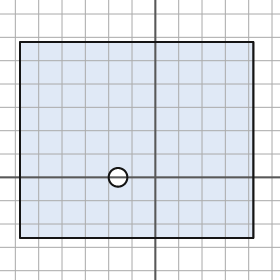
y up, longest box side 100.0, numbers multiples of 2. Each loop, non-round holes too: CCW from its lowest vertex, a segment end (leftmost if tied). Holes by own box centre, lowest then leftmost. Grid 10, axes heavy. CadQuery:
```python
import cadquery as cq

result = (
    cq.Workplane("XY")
    .moveTo(-58.0, -26.0)
    .lineTo(42.0, -26.0)
    .lineTo(42.0, 58.0)
    .lineTo(-58.0, 58.0)
    .close()
    .moveTo(-16.0, 0.0)
    .circle(4.0)
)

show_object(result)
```